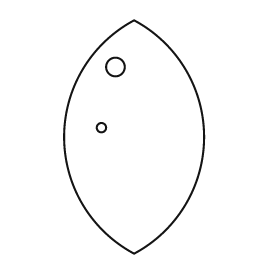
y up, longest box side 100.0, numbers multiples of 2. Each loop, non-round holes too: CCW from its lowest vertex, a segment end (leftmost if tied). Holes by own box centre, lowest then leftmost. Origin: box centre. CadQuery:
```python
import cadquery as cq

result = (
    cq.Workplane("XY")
    .moveTo(0.0, -50.0)
    .threePointArc((30.0, 0.0), (0.0, 50.0))
    .threePointArc((-30.0, 0.0), (0.0, -50.0))
    .close()
    .moveTo(-14.0, 4.0)
    .circle(2.0)
    .moveTo(-8.0, 30.0)
    .circle(4.0)
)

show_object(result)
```